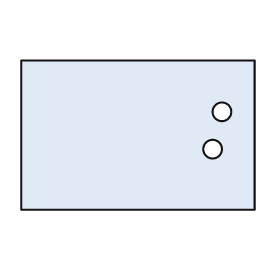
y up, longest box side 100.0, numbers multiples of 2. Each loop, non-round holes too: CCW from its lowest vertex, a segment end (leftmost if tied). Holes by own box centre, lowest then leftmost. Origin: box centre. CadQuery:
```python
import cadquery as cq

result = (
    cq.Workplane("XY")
    .moveTo(-50.0, -32.0)
    .lineTo(50.0, -32.0)
    .lineTo(50.0, 32.0)
    .lineTo(-50.0, 32.0)
    .close()
    .moveTo(32.0, -6.0)
    .circle(4.0)
    .moveTo(36.0, 10.0)
    .circle(4.0)
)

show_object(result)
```